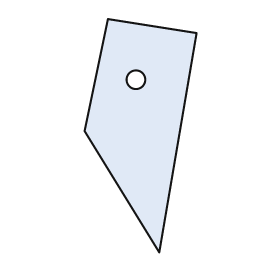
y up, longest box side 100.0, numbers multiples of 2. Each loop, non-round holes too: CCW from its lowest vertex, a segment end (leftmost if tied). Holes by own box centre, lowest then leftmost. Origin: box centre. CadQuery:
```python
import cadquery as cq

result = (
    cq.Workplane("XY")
    .moveTo(8.0, -50.0)
    .lineTo(24.0, 44.0)
    .lineTo(-14.0, 50.0)
    .lineTo(-24.0, 2.0)
    .close()
    .moveTo(-2.0, 24.0)
    .circle(4.0)
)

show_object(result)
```